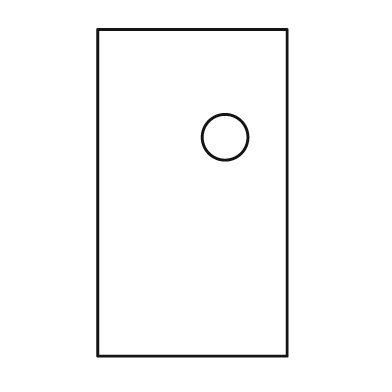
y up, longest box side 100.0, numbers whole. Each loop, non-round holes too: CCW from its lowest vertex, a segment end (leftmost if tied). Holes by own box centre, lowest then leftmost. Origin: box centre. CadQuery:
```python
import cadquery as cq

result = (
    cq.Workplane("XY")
    .moveTo(-29.0, -50.0)
    .lineTo(29.0, -50.0)
    .lineTo(29.0, 50.0)
    .lineTo(-29.0, 50.0)
    .close()
    .moveTo(10.0, 17.0)
    .circle(7.0)
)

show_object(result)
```